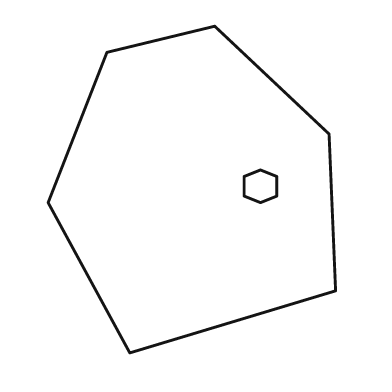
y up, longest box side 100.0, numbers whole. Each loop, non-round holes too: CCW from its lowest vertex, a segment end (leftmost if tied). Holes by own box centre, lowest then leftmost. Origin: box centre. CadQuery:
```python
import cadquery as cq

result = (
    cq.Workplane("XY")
    .moveTo(-19.0, -50.0)
    .lineTo(44.0, -31.0)
    .lineTo(42.0, 17.0)
    .lineTo(7.0, 50.0)
    .lineTo(-26.0, 42.0)
    .lineTo(-44.0, -4.0)
    .close()
    .moveTo(21.0, -4.0)
    .lineTo(26.0, -2.0)
    .lineTo(26.0, 4.0)
    .lineTo(21.0, 6.0)
    .lineTo(16.0, 4.0)
    .lineTo(16.0, -2.0)
    .close()
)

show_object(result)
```